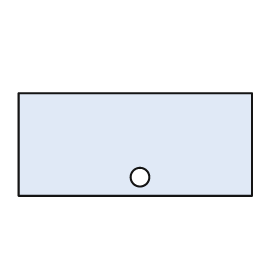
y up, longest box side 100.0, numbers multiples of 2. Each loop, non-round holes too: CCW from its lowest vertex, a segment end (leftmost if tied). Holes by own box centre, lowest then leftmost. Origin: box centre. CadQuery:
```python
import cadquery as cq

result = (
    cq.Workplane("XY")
    .moveTo(-50.0, -22.0)
    .lineTo(50.0, -22.0)
    .lineTo(50.0, 22.0)
    .lineTo(-50.0, 22.0)
    .close()
    .moveTo(2.0, -14.0)
    .circle(4.0)
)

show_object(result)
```